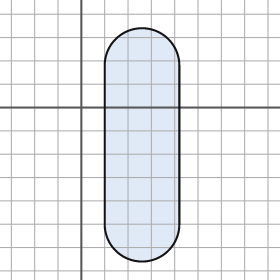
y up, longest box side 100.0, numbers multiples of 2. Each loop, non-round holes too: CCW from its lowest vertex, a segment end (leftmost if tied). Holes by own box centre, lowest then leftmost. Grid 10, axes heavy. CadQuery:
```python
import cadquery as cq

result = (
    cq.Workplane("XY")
    .moveTo(10.0, -50.0)
    .threePointArc((26.0, -66.0), (42.0, -50.0))
    .lineTo(42.0, 18.0)
    .threePointArc((26.0, 34.0), (10.0, 18.0))
    .close()
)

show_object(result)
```